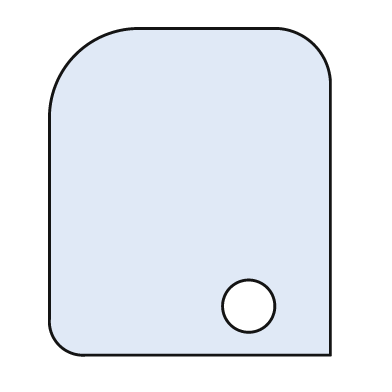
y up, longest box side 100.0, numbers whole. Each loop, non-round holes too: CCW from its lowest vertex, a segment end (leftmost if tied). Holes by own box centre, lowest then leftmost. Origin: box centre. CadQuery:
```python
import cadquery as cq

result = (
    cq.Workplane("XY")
    .moveTo(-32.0, -50.0)
    .lineTo(43.0, -50.0)
    .lineTo(43.0, 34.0)
    .threePointArc((38.0, 45.0), (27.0, 50.0))
    .lineTo(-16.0, 50.0)
    .threePointArc((-35.0, 42.0), (-43.0, 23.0))
    .lineTo(-43.0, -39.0)
    .threePointArc((-40.0, -47.0), (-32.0, -50.0))
    .close()
    .moveTo(18.0, -35.0)
    .circle(8.0)
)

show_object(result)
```